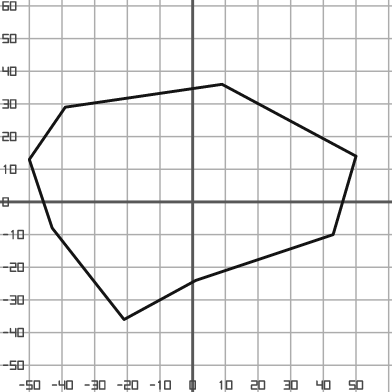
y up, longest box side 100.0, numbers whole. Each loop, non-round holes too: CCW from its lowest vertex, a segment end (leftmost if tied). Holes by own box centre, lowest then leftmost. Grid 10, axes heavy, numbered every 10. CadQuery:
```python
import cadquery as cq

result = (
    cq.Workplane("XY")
    .moveTo(-21.0, -36.0)
    .lineTo(1.0, -24.0)
    .lineTo(43.0, -10.0)
    .lineTo(50.0, 14.0)
    .lineTo(9.0, 36.0)
    .lineTo(-39.0, 29.0)
    .lineTo(-50.0, 13.0)
    .lineTo(-43.0, -8.0)
    .close()
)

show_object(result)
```